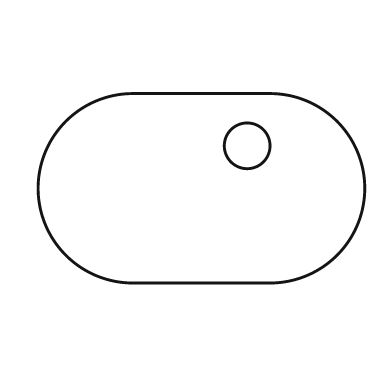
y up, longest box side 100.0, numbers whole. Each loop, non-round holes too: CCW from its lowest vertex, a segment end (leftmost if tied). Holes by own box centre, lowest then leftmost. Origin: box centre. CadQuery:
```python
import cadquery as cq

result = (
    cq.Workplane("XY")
    .moveTo(-21.0, -29.0)
    .lineTo(21.0, -29.0)
    .threePointArc((50.0, 0.0), (21.0, 29.0))
    .lineTo(-21.0, 29.0)
    .threePointArc((-50.0, 0.0), (-21.0, -29.0))
    .close()
    .moveTo(14.0, 13.0)
    .circle(7.0)
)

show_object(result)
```